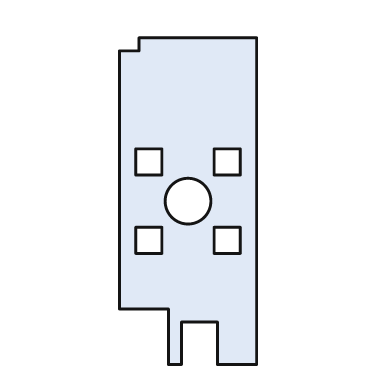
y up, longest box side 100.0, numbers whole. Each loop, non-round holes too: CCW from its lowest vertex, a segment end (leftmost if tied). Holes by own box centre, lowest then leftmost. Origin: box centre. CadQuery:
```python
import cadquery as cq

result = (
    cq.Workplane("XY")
    .moveTo(-6.0, -50.0)
    .lineTo(-2.0, -50.0)
    .lineTo(-2.0, -37.0)
    .lineTo(9.0, -37.0)
    .lineTo(9.0, -50.0)
    .lineTo(21.0, -50.0)
    .lineTo(21.0, 50.0)
    .lineTo(-15.0, 50.0)
    .lineTo(-15.0, 46.0)
    .lineTo(-21.0, 46.0)
    .lineTo(-21.0, -33.0)
    .lineTo(-6.0, -33.0)
    .close()
    .moveTo(-16.0, -16.0)
    .lineTo(-8.0, -16.0)
    .lineTo(-8.0, -8.0)
    .lineTo(-16.0, -8.0)
    .close()
    .moveTo(8.0, -16.0)
    .lineTo(16.0, -16.0)
    .lineTo(16.0, -8.0)
    .lineTo(8.0, -8.0)
    .close()
    .moveTo(0.0, 0.0)
    .circle(7.0)
    .moveTo(-16.0, 8.0)
    .lineTo(-8.0, 8.0)
    .lineTo(-8.0, 16.0)
    .lineTo(-16.0, 16.0)
    .close()
    .moveTo(8.0, 8.0)
    .lineTo(16.0, 8.0)
    .lineTo(16.0, 16.0)
    .lineTo(8.0, 16.0)
    .close()
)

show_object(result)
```